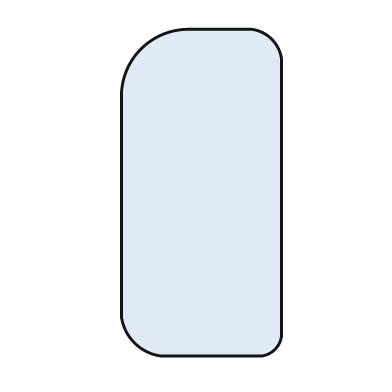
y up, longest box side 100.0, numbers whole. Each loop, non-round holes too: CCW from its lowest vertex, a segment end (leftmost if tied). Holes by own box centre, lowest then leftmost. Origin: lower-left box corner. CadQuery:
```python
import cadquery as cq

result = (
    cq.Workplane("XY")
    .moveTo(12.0, 0.0)
    .lineTo(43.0, 0.0)
    .threePointArc((47.0, 2.0), (49.0, 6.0))
    .lineTo(49.0, 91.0)
    .threePointArc((46.0, 97.0), (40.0, 100.0))
    .lineTo(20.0, 100.0)
    .threePointArc((6.0, 94.0), (0.0, 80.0))
    .lineTo(0.0, 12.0)
    .threePointArc((4.0, 4.0), (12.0, 0.0))
    .close()
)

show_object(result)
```